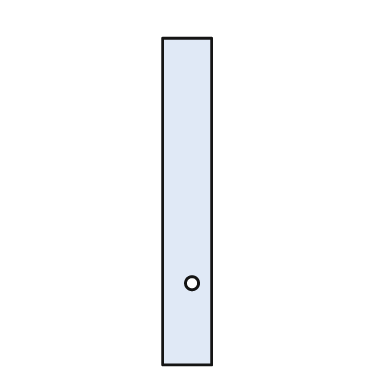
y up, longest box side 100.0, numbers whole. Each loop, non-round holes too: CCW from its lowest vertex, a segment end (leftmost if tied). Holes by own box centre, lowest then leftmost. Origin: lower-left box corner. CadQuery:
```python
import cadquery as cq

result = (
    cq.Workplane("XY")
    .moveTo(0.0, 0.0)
    .lineTo(15.0, 0.0)
    .lineTo(15.0, 100.0)
    .lineTo(0.0, 100.0)
    .close()
    .moveTo(9.0, 25.0)
    .circle(2.0)
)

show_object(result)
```